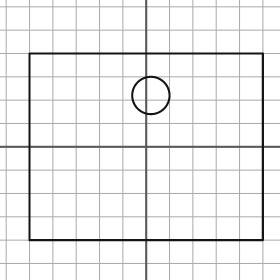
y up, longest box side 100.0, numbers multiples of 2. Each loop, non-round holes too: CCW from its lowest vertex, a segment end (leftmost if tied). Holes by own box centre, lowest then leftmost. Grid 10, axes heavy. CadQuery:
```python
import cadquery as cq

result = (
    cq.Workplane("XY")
    .moveTo(-50.0, -40.0)
    .lineTo(50.0, -40.0)
    .lineTo(50.0, 40.0)
    .lineTo(-50.0, 40.0)
    .close()
    .moveTo(2.0, 22.0)
    .circle(8.0)
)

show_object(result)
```